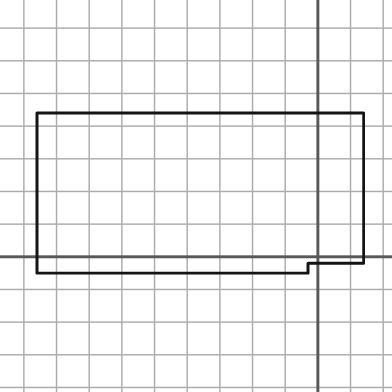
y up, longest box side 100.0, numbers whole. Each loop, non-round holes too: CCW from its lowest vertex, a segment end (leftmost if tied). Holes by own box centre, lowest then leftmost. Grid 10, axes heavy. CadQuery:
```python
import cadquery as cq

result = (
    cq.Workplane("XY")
    .moveTo(-86.0, -5.0)
    .lineTo(-3.0, -5.0)
    .lineTo(-3.0, -2.0)
    .lineTo(14.0, -2.0)
    .lineTo(14.0, 44.0)
    .lineTo(-86.0, 44.0)
    .close()
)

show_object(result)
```